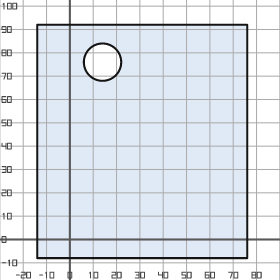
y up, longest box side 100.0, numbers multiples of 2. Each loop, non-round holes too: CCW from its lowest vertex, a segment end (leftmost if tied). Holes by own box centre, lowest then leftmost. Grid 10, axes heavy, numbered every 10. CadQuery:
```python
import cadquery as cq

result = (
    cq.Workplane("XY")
    .moveTo(-14.0, -8.0)
    .lineTo(76.0, -8.0)
    .lineTo(76.0, 92.0)
    .lineTo(-14.0, 92.0)
    .close()
    .moveTo(14.0, 76.0)
    .circle(8.0)
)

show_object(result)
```